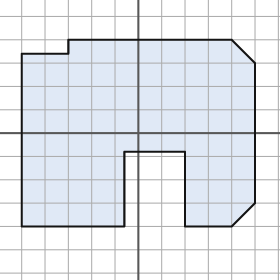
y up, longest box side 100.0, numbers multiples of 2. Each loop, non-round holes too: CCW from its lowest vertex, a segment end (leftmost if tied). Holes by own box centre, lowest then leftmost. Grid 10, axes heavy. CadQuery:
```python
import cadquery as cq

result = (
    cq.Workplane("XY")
    .moveTo(-50.0, -40.0)
    .lineTo(-6.0, -40.0)
    .lineTo(-6.0, -8.0)
    .lineTo(20.0, -8.0)
    .lineTo(20.0, -40.0)
    .lineTo(40.0, -40.0)
    .lineTo(50.0, -30.0)
    .lineTo(50.0, 30.0)
    .lineTo(40.0, 40.0)
    .lineTo(-30.0, 40.0)
    .lineTo(-30.0, 34.0)
    .lineTo(-50.0, 34.0)
    .close()
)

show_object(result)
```